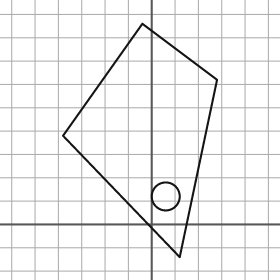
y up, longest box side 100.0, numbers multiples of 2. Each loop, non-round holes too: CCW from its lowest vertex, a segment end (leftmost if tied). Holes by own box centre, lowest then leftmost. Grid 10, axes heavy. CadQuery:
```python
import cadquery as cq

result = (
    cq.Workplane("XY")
    .moveTo(12.0, -14.0)
    .lineTo(28.0, 62.0)
    .lineTo(-4.0, 86.0)
    .lineTo(-38.0, 38.0)
    .close()
    .moveTo(6.0, 12.0)
    .circle(6.0)
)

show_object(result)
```